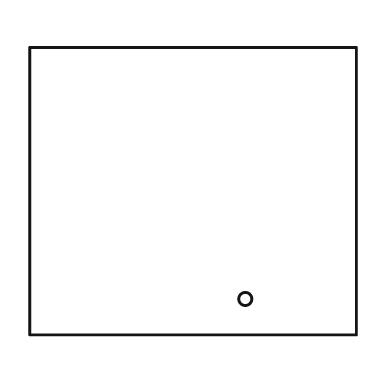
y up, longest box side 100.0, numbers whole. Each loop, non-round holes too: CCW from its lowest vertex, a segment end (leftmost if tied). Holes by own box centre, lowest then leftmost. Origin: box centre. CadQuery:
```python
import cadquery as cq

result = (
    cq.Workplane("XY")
    .moveTo(-50.0, -44.0)
    .lineTo(50.0, -44.0)
    .lineTo(50.0, 44.0)
    .lineTo(-50.0, 44.0)
    .close()
    .moveTo(16.0, -33.0)
    .circle(2.0)
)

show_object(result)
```